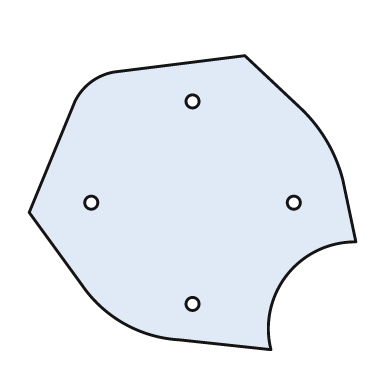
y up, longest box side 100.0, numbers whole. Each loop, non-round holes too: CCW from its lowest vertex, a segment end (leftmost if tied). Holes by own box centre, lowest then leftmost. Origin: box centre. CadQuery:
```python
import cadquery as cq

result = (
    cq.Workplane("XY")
    .moveTo(24.0, -45.0)
    .threePointArc((29.0, -22.0), (50.0, -12.0))
    .lineTo(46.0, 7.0)
    .threePointArc((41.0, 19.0), (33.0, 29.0))
    .lineTo(16.0, 45.0)
    .lineTo(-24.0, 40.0)
    .threePointArc((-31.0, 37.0), (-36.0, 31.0))
    .lineTo(-50.0, -3.0)
    .lineTo(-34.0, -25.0)
    .threePointArc((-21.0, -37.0), (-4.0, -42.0))
    .close()
    .moveTo(0.0, -31.0)
    .circle(2.0)
    .moveTo(-31.0, 0.0)
    .circle(2.0)
    .moveTo(31.0, 0.0)
    .circle(2.0)
    .moveTo(0.0, 31.0)
    .circle(2.0)
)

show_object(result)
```